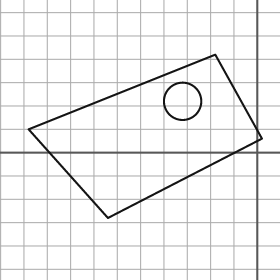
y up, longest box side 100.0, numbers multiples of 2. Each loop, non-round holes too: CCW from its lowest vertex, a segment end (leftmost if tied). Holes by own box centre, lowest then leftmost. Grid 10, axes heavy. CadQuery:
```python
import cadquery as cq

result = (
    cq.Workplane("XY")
    .moveTo(-64.0, -28.0)
    .lineTo(2.0, 6.0)
    .lineTo(-18.0, 42.0)
    .lineTo(-98.0, 10.0)
    .close()
    .moveTo(-32.0, 22.0)
    .circle(8.0)
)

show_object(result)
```